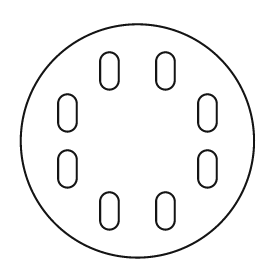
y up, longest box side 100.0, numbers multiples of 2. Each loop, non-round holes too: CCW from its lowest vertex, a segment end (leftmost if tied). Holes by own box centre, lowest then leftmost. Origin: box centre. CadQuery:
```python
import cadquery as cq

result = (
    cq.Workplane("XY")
    .moveTo(0.0, 0.0)
    .circle(50.0)
    .moveTo(-16.0, -34.0)
    .threePointArc((-12.0, -38.0), (-8.0, -34.0))
    .lineTo(-8.0, -26.0)
    .threePointArc((-12.0, -22.0), (-16.0, -26.0))
    .close()
    .moveTo(8.0, -34.0)
    .threePointArc((12.0, -38.0), (16.0, -34.0))
    .lineTo(16.0, -26.0)
    .threePointArc((12.0, -22.0), (8.0, -26.0))
    .close()
    .moveTo(-34.0, -16.0)
    .threePointArc((-30.0, -20.0), (-26.0, -16.0))
    .lineTo(-26.0, -8.0)
    .threePointArc((-30.0, -4.0), (-34.0, -8.0))
    .close()
    .moveTo(26.0, -16.0)
    .threePointArc((30.0, -20.0), (34.0, -16.0))
    .lineTo(34.0, -8.0)
    .threePointArc((30.0, -4.0), (26.0, -8.0))
    .close()
    .moveTo(-34.0, 8.0)
    .threePointArc((-30.0, 4.0), (-26.0, 8.0))
    .lineTo(-26.0, 16.0)
    .threePointArc((-30.0, 20.0), (-34.0, 16.0))
    .close()
    .moveTo(26.0, 8.0)
    .threePointArc((30.0, 4.0), (34.0, 8.0))
    .lineTo(34.0, 16.0)
    .threePointArc((30.0, 20.0), (26.0, 16.0))
    .close()
    .moveTo(-16.0, 26.0)
    .threePointArc((-12.0, 22.0), (-8.0, 26.0))
    .lineTo(-8.0, 34.0)
    .threePointArc((-12.0, 38.0), (-16.0, 34.0))
    .close()
    .moveTo(8.0, 26.0)
    .threePointArc((12.0, 22.0), (16.0, 26.0))
    .lineTo(16.0, 34.0)
    .threePointArc((12.0, 38.0), (8.0, 34.0))
    .close()
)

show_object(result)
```